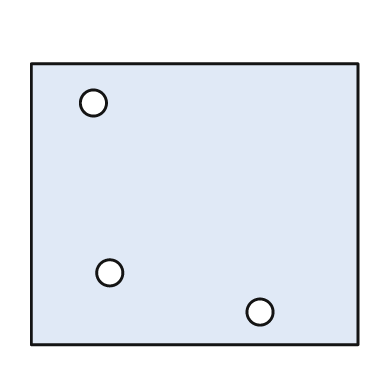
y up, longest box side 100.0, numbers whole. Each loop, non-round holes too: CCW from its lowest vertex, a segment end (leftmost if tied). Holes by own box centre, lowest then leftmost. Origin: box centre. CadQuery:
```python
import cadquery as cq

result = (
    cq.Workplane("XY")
    .moveTo(-50.0, -43.0)
    .lineTo(50.0, -43.0)
    .lineTo(50.0, 43.0)
    .lineTo(-50.0, 43.0)
    .close()
    .moveTo(20.0, -33.0)
    .circle(4.0)
    .moveTo(-26.0, -21.0)
    .circle(4.0)
    .moveTo(-31.0, 31.0)
    .circle(4.0)
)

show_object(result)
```